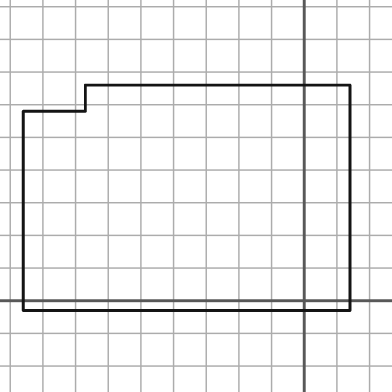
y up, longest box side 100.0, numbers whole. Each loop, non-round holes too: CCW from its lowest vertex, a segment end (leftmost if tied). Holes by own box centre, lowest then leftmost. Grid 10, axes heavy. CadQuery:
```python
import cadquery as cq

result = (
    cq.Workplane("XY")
    .moveTo(-86.0, -3.0)
    .lineTo(14.0, -3.0)
    .lineTo(14.0, 66.0)
    .lineTo(-67.0, 66.0)
    .lineTo(-67.0, 58.0)
    .lineTo(-86.0, 58.0)
    .close()
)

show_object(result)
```